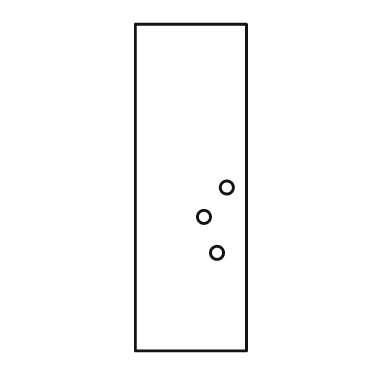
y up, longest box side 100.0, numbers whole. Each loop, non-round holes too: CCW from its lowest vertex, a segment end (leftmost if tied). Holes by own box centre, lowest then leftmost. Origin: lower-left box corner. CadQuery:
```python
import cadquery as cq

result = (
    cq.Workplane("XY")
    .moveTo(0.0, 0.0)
    .lineTo(34.0, 0.0)
    .lineTo(34.0, 100.0)
    .lineTo(0.0, 100.0)
    .close()
    .moveTo(25.0, 30.0)
    .circle(2.0)
    .moveTo(21.0, 41.0)
    .circle(2.0)
    .moveTo(28.0, 50.0)
    .circle(2.0)
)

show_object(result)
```